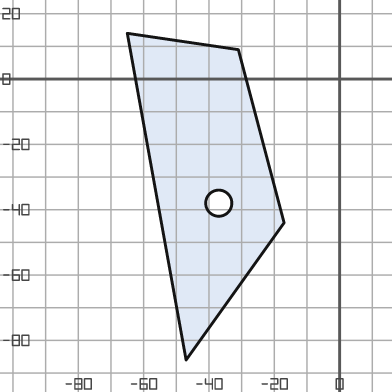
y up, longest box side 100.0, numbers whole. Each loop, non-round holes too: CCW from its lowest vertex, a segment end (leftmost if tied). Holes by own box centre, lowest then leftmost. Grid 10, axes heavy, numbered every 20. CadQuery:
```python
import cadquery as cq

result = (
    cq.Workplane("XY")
    .moveTo(-47.0, -86.0)
    .lineTo(-17.0, -44.0)
    .lineTo(-31.0, 9.0)
    .lineTo(-65.0, 14.0)
    .close()
    .moveTo(-37.0, -38.0)
    .circle(4.0)
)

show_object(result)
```